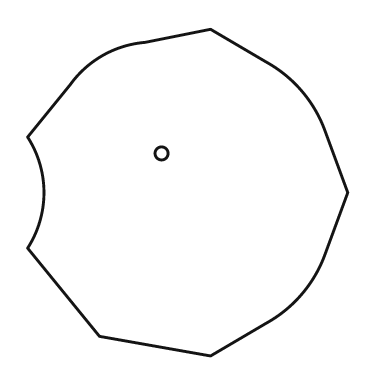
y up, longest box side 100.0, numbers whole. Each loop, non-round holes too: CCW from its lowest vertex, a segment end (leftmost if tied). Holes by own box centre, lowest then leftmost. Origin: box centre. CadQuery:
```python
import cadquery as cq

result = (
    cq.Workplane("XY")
    .moveTo(7.0, -50.0)
    .lineTo(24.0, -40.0)
    .threePointArc((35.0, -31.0), (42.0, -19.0))
    .lineTo(49.0, 0.0)
    .lineTo(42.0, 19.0)
    .threePointArc((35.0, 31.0), (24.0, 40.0))
    .lineTo(7.0, 50.0)
    .lineTo(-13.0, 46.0)
    .threePointArc((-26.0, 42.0), (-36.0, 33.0))
    .lineTo(-49.0, 17.0)
    .threePointArc((-44.0, 0.0), (-49.0, -17.0))
    .lineTo(-27.0, -44.0)
    .close()
    .moveTo(-8.0, 12.0)
    .circle(2.0)
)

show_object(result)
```